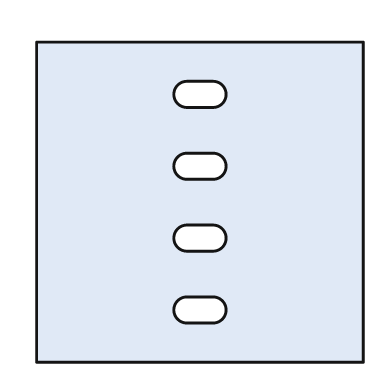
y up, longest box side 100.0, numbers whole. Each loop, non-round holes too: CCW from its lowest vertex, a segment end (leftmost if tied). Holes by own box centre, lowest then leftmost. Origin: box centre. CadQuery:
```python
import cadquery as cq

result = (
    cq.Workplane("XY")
    .moveTo(-50.0, -49.0)
    .lineTo(50.0, -49.0)
    .lineTo(50.0, 49.0)
    .lineTo(-50.0, 49.0)
    .close()
    .moveTo(-4.0, -37.0)
    .lineTo(4.0, -37.0)
    .threePointArc((8.0, -33.0), (4.0, -29.0))
    .lineTo(-4.0, -29.0)
    .threePointArc((-8.0, -33.0), (-4.0, -37.0))
    .close()
    .moveTo(-4.0, -15.0)
    .lineTo(4.0, -15.0)
    .threePointArc((8.0, -11.0), (4.0, -7.0))
    .lineTo(-4.0, -7.0)
    .threePointArc((-8.0, -11.0), (-4.0, -15.0))
    .close()
    .moveTo(-4.0, 7.0)
    .lineTo(4.0, 7.0)
    .threePointArc((8.0, 11.0), (4.0, 15.0))
    .lineTo(-4.0, 15.0)
    .threePointArc((-8.0, 11.0), (-4.0, 7.0))
    .close()
    .moveTo(-4.0, 29.0)
    .lineTo(4.0, 29.0)
    .threePointArc((8.0, 33.0), (4.0, 37.0))
    .lineTo(-4.0, 37.0)
    .threePointArc((-8.0, 33.0), (-4.0, 29.0))
    .close()
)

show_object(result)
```